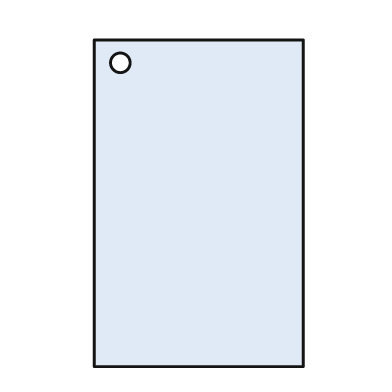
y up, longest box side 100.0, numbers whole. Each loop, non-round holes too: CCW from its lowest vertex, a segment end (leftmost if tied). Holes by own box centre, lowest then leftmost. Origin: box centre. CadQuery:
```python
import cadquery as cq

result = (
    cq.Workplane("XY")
    .moveTo(-32.0, -50.0)
    .lineTo(32.0, -50.0)
    .lineTo(32.0, 50.0)
    .lineTo(-32.0, 50.0)
    .close()
    .moveTo(-24.0, 43.0)
    .circle(3.0)
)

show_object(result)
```